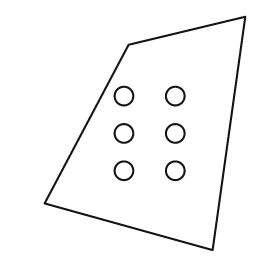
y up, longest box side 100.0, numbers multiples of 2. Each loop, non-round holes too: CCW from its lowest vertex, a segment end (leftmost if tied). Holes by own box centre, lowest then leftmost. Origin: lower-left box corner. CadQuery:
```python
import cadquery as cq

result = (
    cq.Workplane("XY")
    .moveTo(72.0, 0.0)
    .lineTo(86.0, 100.0)
    .lineTo(36.0, 88.0)
    .lineTo(0.0, 20.0)
    .close()
    .moveTo(34.0, 34.0)
    .circle(4.0)
    .moveTo(56.0, 34.0)
    .circle(4.0)
    .moveTo(34.0, 50.0)
    .circle(4.0)
    .moveTo(56.0, 50.0)
    .circle(4.0)
    .moveTo(34.0, 66.0)
    .circle(4.0)
    .moveTo(56.0, 66.0)
    .circle(4.0)
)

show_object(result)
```